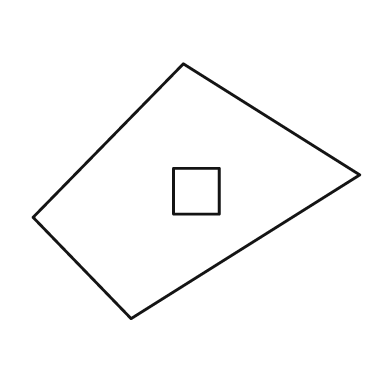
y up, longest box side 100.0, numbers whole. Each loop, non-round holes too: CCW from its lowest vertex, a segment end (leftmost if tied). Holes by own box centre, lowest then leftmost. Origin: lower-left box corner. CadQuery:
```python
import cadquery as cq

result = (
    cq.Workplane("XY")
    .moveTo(30.0, 0.0)
    .lineTo(100.0, 44.0)
    .lineTo(46.0, 78.0)
    .lineTo(0.0, 31.0)
    .close()
    .moveTo(43.0, 32.0)
    .lineTo(57.0, 32.0)
    .lineTo(57.0, 46.0)
    .lineTo(43.0, 46.0)
    .close()
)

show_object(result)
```